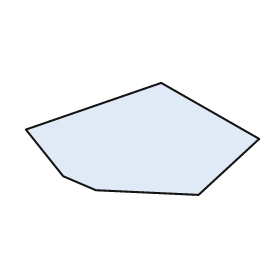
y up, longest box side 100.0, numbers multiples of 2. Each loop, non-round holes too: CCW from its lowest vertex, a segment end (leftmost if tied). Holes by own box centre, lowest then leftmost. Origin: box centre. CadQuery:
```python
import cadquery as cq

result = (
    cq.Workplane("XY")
    .moveTo(24.0, -24.0)
    .lineTo(50.0, 0.0)
    .lineTo(8.0, 24.0)
    .lineTo(-50.0, 4.0)
    .lineTo(-34.0, -16.0)
    .lineTo(-20.0, -22.0)
    .close()
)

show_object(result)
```